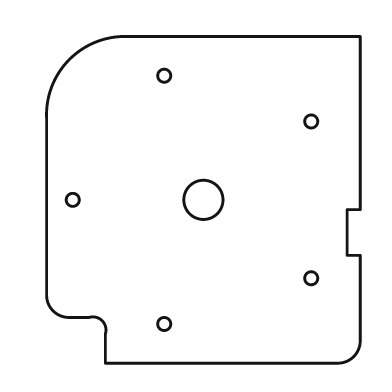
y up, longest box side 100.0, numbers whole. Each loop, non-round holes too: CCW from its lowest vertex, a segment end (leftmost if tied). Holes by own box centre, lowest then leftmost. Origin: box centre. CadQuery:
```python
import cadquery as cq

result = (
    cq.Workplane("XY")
    .moveTo(-30.0, -50.0)
    .lineTo(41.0, -50.0)
    .threePointArc((46.0, -48.0), (48.0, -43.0))
    .lineTo(48.0, -17.0)
    .lineTo(44.0, -17.0)
    .lineTo(44.0, -3.0)
    .lineTo(48.0, -3.0)
    .lineTo(48.0, 50.0)
    .lineTo(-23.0, 50.0)
    .threePointArc((-41.0, 43.0), (-48.0, 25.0))
    .lineTo(-48.0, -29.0)
    .threePointArc((-46.0, -34.0), (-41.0, -36.0))
    .lineTo(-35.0, -36.0)
    .threePointArc((-31.0, -37.0), (-30.0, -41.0))
    .close()
    .moveTo(-12.0, -38.0)
    .circle(2.0)
    .moveTo(33.0, -24.0)
    .circle(2.0)
    .moveTo(-40.0, 0.0)
    .circle(2.0)
    .moveTo(0.0, 0.0)
    .circle(6.0)
    .moveTo(33.0, 24.0)
    .circle(2.0)
    .moveTo(-12.0, 38.0)
    .circle(2.0)
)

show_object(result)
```